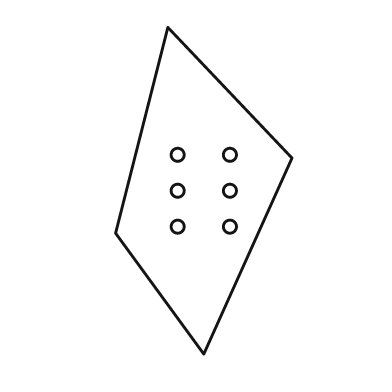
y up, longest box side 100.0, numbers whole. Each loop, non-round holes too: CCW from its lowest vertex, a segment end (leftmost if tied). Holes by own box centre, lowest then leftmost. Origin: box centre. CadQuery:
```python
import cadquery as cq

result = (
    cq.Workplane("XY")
    .moveTo(0.0, -50.0)
    .lineTo(27.0, 10.0)
    .lineTo(-11.0, 50.0)
    .lineTo(-27.0, -13.0)
    .close()
    .moveTo(-8.0, -11.0)
    .circle(2.0)
    .moveTo(8.0, -11.0)
    .circle(2.0)
    .moveTo(-8.0, 0.0)
    .circle(2.0)
    .moveTo(8.0, 0.0)
    .circle(2.0)
    .moveTo(-8.0, 11.0)
    .circle(2.0)
    .moveTo(8.0, 11.0)
    .circle(2.0)
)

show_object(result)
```